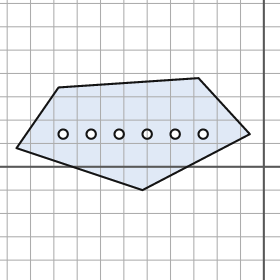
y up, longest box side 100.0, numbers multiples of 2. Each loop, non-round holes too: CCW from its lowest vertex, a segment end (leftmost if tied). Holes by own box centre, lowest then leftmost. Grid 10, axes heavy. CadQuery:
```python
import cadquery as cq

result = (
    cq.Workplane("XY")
    .moveTo(-52.0, -10.0)
    .lineTo(-6.0, 14.0)
    .lineTo(-28.0, 38.0)
    .lineTo(-88.0, 34.0)
    .lineTo(-106.0, 8.0)
    .close()
    .moveTo(-86.0, 14.0)
    .circle(2.0)
    .moveTo(-74.0, 14.0)
    .circle(2.0)
    .moveTo(-62.0, 14.0)
    .circle(2.0)
    .moveTo(-50.0, 14.0)
    .circle(2.0)
    .moveTo(-38.0, 14.0)
    .circle(2.0)
    .moveTo(-26.0, 14.0)
    .circle(2.0)
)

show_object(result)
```